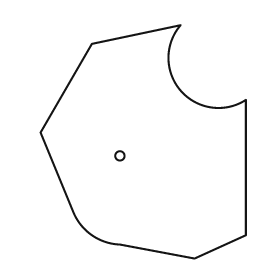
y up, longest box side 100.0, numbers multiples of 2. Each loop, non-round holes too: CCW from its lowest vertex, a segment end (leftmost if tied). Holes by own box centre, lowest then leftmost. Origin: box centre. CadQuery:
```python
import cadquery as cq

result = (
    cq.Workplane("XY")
    .moveTo(22.0, -50.0)
    .lineTo(44.0, -40.0)
    .lineTo(44.0, 18.0)
    .threePointArc((16.0, 22.0), (16.0, 50.0))
    .lineTo(-22.0, 42.0)
    .lineTo(-44.0, 4.0)
    .lineTo(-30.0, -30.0)
    .threePointArc((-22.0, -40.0), (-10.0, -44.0))
    .close()
    .moveTo(-10.0, -6.0)
    .circle(2.0)
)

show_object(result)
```